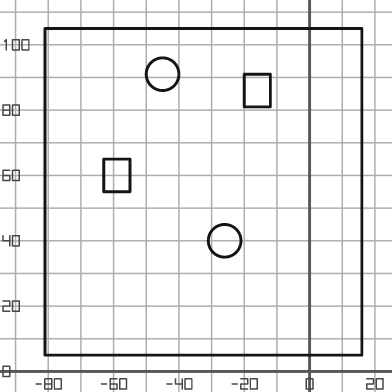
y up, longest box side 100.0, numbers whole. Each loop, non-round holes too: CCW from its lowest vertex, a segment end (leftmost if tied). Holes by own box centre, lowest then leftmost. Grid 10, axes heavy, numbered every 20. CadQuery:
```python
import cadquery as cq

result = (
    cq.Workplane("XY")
    .moveTo(-81.0, 5.0)
    .lineTo(16.0, 5.0)
    .lineTo(16.0, 105.0)
    .lineTo(-81.0, 105.0)
    .close()
    .moveTo(-26.0, 40.0)
    .circle(5.0)
    .moveTo(-63.0, 55.0)
    .lineTo(-55.0, 55.0)
    .lineTo(-55.0, 65.0)
    .lineTo(-63.0, 65.0)
    .close()
    .moveTo(-20.0, 81.0)
    .lineTo(-12.0, 81.0)
    .lineTo(-12.0, 91.0)
    .lineTo(-20.0, 91.0)
    .close()
    .moveTo(-45.0, 91.0)
    .circle(5.0)
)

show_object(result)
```